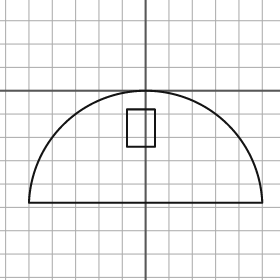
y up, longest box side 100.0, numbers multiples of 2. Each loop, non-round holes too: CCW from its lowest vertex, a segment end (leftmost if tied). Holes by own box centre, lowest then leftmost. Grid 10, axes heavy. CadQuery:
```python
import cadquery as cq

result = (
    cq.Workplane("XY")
    .moveTo(-50.0, -48.0)
    .lineTo(50.0, -48.0)
    .threePointArc((0.0, 0.0), (-50.0, -48.0))
    .close()
    .moveTo(-8.0, -24.0)
    .lineTo(4.0, -24.0)
    .lineTo(4.0, -8.0)
    .lineTo(-8.0, -8.0)
    .close()
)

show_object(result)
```